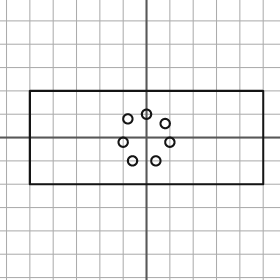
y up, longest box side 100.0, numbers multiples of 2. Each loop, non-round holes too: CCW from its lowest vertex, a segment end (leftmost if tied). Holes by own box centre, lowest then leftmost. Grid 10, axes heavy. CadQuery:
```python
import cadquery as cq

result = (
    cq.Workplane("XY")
    .moveTo(-50.0, -20.0)
    .lineTo(50.0, -20.0)
    .lineTo(50.0, 20.0)
    .lineTo(-50.0, 20.0)
    .close()
    .moveTo(-6.0, -10.0)
    .circle(2.0)
    .moveTo(4.0, -10.0)
    .circle(2.0)
    .moveTo(-10.0, -2.0)
    .circle(2.0)
    .moveTo(10.0, -2.0)
    .circle(2.0)
    .moveTo(8.0, 6.0)
    .circle(2.0)
    .moveTo(-8.0, 8.0)
    .circle(2.0)
    .moveTo(0.0, 10.0)
    .circle(2.0)
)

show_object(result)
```